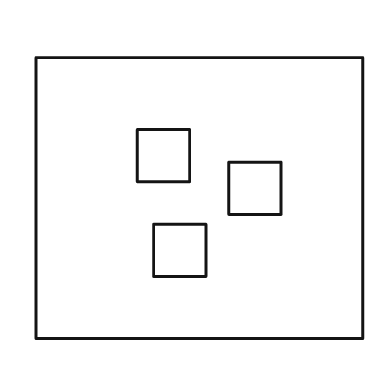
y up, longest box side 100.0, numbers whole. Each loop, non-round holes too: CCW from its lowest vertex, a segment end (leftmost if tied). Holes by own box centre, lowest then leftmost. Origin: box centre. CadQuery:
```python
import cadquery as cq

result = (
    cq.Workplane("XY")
    .moveTo(-50.0, -43.0)
    .lineTo(50.0, -43.0)
    .lineTo(50.0, 43.0)
    .lineTo(-50.0, 43.0)
    .close()
    .moveTo(-14.0, -24.0)
    .lineTo(2.0, -24.0)
    .lineTo(2.0, -8.0)
    .lineTo(-14.0, -8.0)
    .close()
    .moveTo(9.0, -5.0)
    .lineTo(25.0, -5.0)
    .lineTo(25.0, 11.0)
    .lineTo(9.0, 11.0)
    .close()
    .moveTo(-19.0, 5.0)
    .lineTo(-3.0, 5.0)
    .lineTo(-3.0, 21.0)
    .lineTo(-19.0, 21.0)
    .close()
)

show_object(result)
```